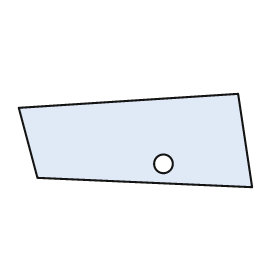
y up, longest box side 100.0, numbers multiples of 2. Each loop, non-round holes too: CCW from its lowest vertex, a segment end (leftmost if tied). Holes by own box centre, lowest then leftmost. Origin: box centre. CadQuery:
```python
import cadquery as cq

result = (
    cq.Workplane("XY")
    .moveTo(50.0, -20.0)
    .lineTo(44.0, 20.0)
    .lineTo(-50.0, 14.0)
    .lineTo(-42.0, -16.0)
    .close()
    .moveTo(12.0, -10.0)
    .circle(4.0)
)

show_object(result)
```